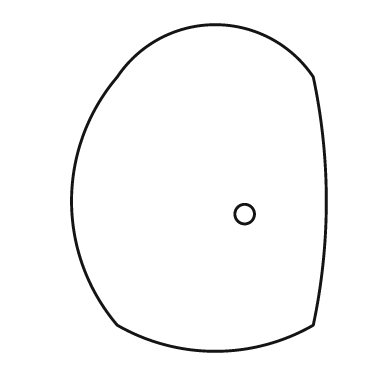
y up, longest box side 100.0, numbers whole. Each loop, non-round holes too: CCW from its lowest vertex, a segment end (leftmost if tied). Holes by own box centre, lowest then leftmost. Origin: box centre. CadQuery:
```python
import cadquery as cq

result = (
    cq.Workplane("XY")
    .moveTo(-25.0, -42.0)
    .threePointArc((5.0, -50.0), (35.0, -42.0))
    .threePointArc((39.0, -4.0), (35.0, 34.0))
    .threePointArc((5.0, 50.0), (-25.0, 34.0))
    .threePointArc((-39.0, -4.0), (-25.0, -42.0))
    .close()
    .moveTo(14.0, -8.0)
    .circle(3.0)
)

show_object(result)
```